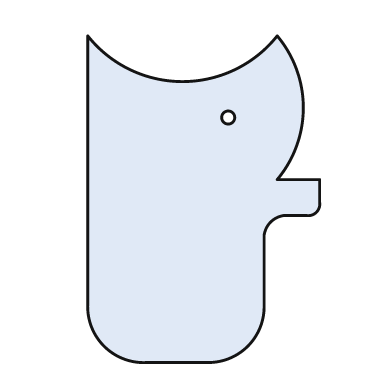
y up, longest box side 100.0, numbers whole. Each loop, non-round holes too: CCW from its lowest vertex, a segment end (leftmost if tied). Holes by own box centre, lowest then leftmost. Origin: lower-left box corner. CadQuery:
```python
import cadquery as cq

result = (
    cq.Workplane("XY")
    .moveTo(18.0, 0.0)
    .lineTo(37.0, 0.0)
    .threePointArc((49.0, 5.0), (54.0, 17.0))
    .lineTo(54.0, 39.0)
    .threePointArc((56.0, 43.0), (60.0, 45.0))
    .lineTo(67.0, 45.0)
    .threePointArc((70.0, 46.0), (71.0, 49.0))
    .lineTo(71.0, 56.0)
    .lineTo(58.0, 56.0)
    .threePointArc((66.0, 78.0), (58.0, 100.0))
    .threePointArc((29.0, 86.0), (0.0, 100.0))
    .lineTo(0.0, 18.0)
    .threePointArc((5.0, 5.0), (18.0, 0.0))
    .close()
    .moveTo(43.0, 75.0)
    .circle(2.0)
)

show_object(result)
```